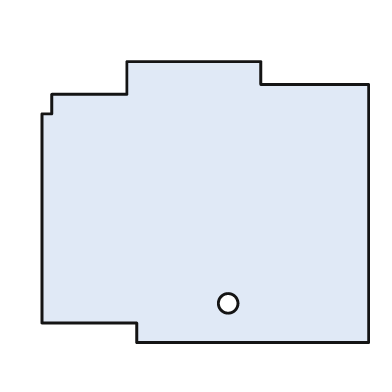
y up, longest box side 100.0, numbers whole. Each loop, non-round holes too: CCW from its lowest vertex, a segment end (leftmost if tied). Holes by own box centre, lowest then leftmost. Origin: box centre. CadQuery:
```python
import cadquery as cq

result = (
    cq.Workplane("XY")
    .moveTo(-21.0, -43.0)
    .lineTo(50.0, -43.0)
    .lineTo(50.0, 36.0)
    .lineTo(17.0, 36.0)
    .lineTo(17.0, 43.0)
    .lineTo(-24.0, 43.0)
    .lineTo(-24.0, 33.0)
    .lineTo(-47.0, 33.0)
    .lineTo(-47.0, 27.0)
    .lineTo(-50.0, 27.0)
    .lineTo(-50.0, -37.0)
    .lineTo(-21.0, -37.0)
    .close()
    .moveTo(7.0, -31.0)
    .circle(3.0)
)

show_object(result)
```